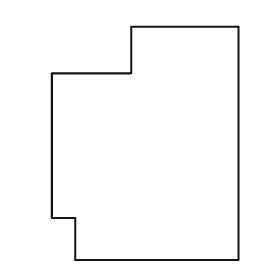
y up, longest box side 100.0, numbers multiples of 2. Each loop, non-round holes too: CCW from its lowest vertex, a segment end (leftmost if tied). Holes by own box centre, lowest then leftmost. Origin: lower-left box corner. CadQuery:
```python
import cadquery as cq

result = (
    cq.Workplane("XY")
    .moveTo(10.0, 0.0)
    .lineTo(80.0, 0.0)
    .lineTo(80.0, 100.0)
    .lineTo(34.0, 100.0)
    .lineTo(34.0, 80.0)
    .lineTo(0.0, 80.0)
    .lineTo(0.0, 18.0)
    .lineTo(10.0, 18.0)
    .close()
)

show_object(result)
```